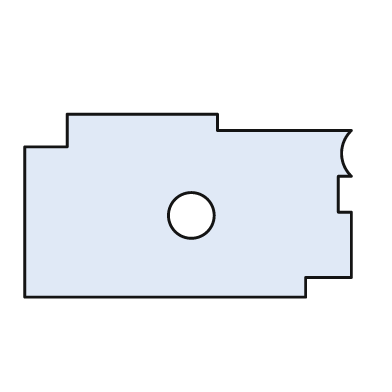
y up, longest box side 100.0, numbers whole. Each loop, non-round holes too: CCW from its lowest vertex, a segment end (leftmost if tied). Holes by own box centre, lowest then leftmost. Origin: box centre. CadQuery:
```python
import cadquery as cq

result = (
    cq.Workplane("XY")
    .moveTo(-50.0, -28.0)
    .lineTo(36.0, -28.0)
    .lineTo(36.0, -22.0)
    .lineTo(50.0, -22.0)
    .lineTo(50.0, -2.0)
    .lineTo(46.0, -2.0)
    .lineTo(46.0, 9.0)
    .lineTo(50.0, 9.0)
    .threePointArc((47.0, 16.0), (50.0, 23.0))
    .lineTo(9.0, 23.0)
    .lineTo(9.0, 28.0)
    .lineTo(-37.0, 28.0)
    .lineTo(-37.0, 18.0)
    .lineTo(-50.0, 18.0)
    .close()
    .moveTo(1.0, -3.0)
    .circle(7.0)
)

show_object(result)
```